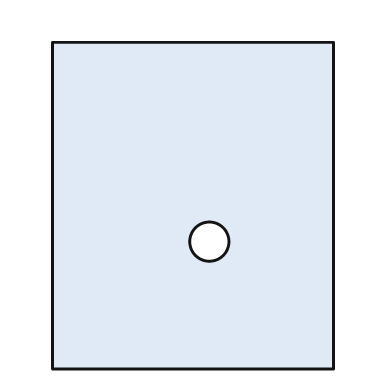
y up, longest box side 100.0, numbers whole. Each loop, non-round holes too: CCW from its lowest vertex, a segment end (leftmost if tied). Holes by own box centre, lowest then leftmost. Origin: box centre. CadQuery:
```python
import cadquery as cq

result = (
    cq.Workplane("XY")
    .moveTo(-43.0, -50.0)
    .lineTo(43.0, -50.0)
    .lineTo(43.0, 50.0)
    .lineTo(-43.0, 50.0)
    .close()
    .moveTo(5.0, -11.0)
    .circle(6.0)
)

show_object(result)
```